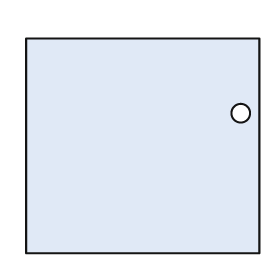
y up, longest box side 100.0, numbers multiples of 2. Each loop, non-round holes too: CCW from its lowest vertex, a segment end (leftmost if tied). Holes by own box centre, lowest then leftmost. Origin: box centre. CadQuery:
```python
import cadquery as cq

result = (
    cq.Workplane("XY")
    .moveTo(-50.0, -46.0)
    .lineTo(50.0, -46.0)
    .lineTo(50.0, 46.0)
    .lineTo(-50.0, 46.0)
    .close()
    .moveTo(42.0, 14.0)
    .circle(4.0)
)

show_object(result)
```